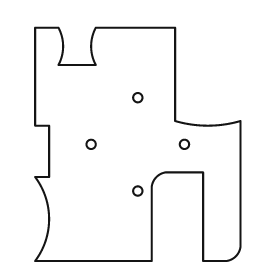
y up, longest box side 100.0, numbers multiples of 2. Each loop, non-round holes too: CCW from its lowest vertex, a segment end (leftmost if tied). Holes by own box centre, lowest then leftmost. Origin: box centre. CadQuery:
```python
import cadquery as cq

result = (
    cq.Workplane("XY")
    .moveTo(-44.0, -50.0)
    .lineTo(6.0, -50.0)
    .lineTo(6.0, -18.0)
    .threePointArc((8.0, -14.0), (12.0, -12.0))
    .lineTo(28.0, -12.0)
    .lineTo(28.0, -50.0)
    .lineTo(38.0, -50.0)
    .threePointArc((42.0, -48.0), (44.0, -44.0))
    .lineTo(44.0, 10.0)
    .threePointArc((30.0, 8.0), (16.0, 10.0))
    .lineTo(16.0, 50.0)
    .lineTo(-18.0, 50.0)
    .threePointArc((-20.0, 42.0), (-18.0, 34.0))
    .lineTo(-34.0, 34.0)
    .threePointArc((-32.0, 42.0), (-34.0, 50.0))
    .lineTo(-44.0, 50.0)
    .lineTo(-44.0, 8.0)
    .lineTo(-38.0, 8.0)
    .lineTo(-38.0, -14.0)
    .lineTo(-44.0, -14.0)
    .threePointArc((-38.0, -32.0), (-44.0, -50.0))
    .close()
    .moveTo(0.0, -20.0)
    .circle(2.0)
    .moveTo(-20.0, 0.0)
    .circle(2.0)
    .moveTo(20.0, 0.0)
    .circle(2.0)
    .moveTo(0.0, 20.0)
    .circle(2.0)
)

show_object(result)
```